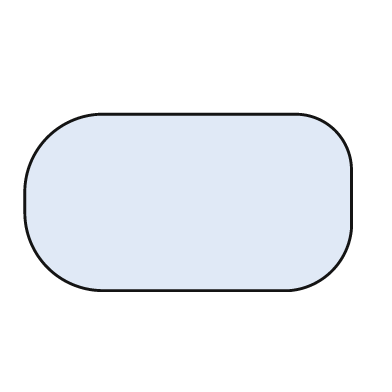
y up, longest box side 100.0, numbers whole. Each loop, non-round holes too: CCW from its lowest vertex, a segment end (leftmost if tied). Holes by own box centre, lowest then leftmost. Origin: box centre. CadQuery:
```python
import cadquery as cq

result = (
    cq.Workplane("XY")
    .moveTo(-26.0, -27.0)
    .lineTo(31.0, -27.0)
    .threePointArc((44.0, -21.0), (50.0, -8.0))
    .lineTo(50.0, 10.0)
    .threePointArc((45.0, 22.0), (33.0, 27.0))
    .lineTo(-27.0, 27.0)
    .threePointArc((-43.0, 20.0), (-50.0, 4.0))
    .lineTo(-50.0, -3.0)
    .threePointArc((-43.0, -20.0), (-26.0, -27.0))
    .close()
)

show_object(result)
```